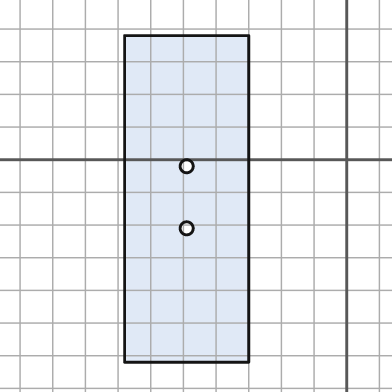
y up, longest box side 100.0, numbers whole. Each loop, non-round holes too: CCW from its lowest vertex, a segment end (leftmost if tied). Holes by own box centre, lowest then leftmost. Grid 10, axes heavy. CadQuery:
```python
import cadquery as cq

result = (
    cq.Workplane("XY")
    .moveTo(-68.0, -62.0)
    .lineTo(-30.0, -62.0)
    .lineTo(-30.0, 38.0)
    .lineTo(-68.0, 38.0)
    .close()
    .moveTo(-49.0, -21.0)
    .circle(2.0)
    .moveTo(-49.0, -2.0)
    .circle(2.0)
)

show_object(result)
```